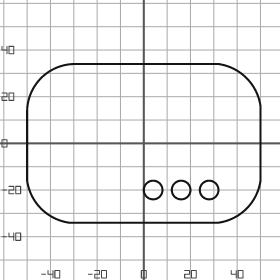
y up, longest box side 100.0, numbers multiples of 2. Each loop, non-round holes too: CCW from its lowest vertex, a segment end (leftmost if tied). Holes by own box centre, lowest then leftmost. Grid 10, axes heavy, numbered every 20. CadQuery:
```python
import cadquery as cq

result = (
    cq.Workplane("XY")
    .moveTo(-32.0, -34.0)
    .lineTo(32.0, -34.0)
    .threePointArc((44.0, -28.0), (50.0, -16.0))
    .lineTo(50.0, 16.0)
    .threePointArc((44.0, 28.0), (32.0, 34.0))
    .lineTo(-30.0, 34.0)
    .threePointArc((-44.0, 28.0), (-50.0, 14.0))
    .lineTo(-50.0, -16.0)
    .threePointArc((-44.0, -28.0), (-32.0, -34.0))
    .close()
    .moveTo(4.0, -20.0)
    .circle(4.0)
    .moveTo(16.0, -20.0)
    .circle(4.0)
    .moveTo(28.0, -20.0)
    .circle(4.0)
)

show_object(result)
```